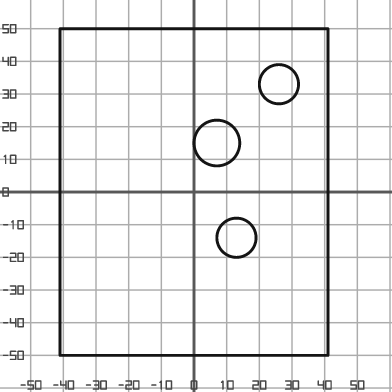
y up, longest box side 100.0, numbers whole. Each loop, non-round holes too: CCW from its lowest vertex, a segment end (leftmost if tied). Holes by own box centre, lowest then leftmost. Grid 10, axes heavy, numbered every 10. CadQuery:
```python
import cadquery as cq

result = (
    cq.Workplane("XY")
    .moveTo(-41.0, -50.0)
    .lineTo(41.0, -50.0)
    .lineTo(41.0, 50.0)
    .lineTo(-41.0, 50.0)
    .close()
    .moveTo(13.0, -14.0)
    .circle(6.0)
    .moveTo(7.0, 15.0)
    .circle(7.0)
    .moveTo(26.0, 33.0)
    .circle(6.0)
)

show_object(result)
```